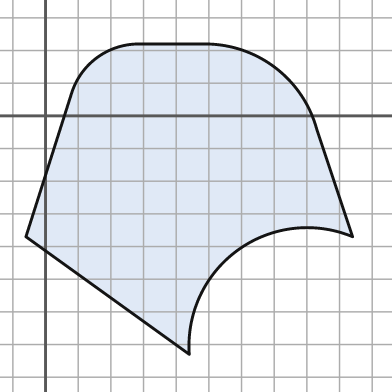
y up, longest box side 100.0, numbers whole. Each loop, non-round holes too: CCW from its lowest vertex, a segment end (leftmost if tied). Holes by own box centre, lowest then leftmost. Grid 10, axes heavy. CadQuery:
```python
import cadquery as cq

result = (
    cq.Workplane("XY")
    .moveTo(44.0, -73.0)
    .threePointArc((59.0, -41.0), (94.0, -37.0))
    .lineTo(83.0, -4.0)
    .threePointArc((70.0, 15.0), (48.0, 22.0))
    .lineTo(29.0, 22.0)
    .threePointArc((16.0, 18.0), (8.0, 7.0))
    .lineTo(-6.0, -37.0)
    .close()
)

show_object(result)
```